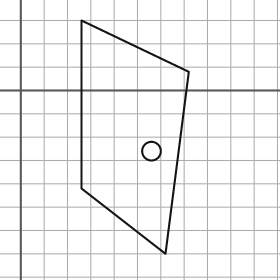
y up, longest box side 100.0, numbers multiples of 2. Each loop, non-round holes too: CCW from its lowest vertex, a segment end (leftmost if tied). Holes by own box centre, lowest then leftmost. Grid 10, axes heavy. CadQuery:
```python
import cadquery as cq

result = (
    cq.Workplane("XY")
    .moveTo(62.0, -70.0)
    .lineTo(72.0, 8.0)
    .lineTo(26.0, 30.0)
    .lineTo(26.0, -42.0)
    .close()
    .moveTo(56.0, -26.0)
    .circle(4.0)
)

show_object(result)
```